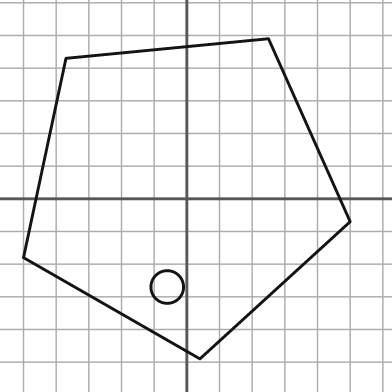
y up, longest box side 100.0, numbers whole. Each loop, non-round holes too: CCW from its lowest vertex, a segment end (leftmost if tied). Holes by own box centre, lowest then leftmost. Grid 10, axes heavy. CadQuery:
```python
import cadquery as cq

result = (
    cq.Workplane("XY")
    .moveTo(4.0, -49.0)
    .lineTo(50.0, -7.0)
    .lineTo(25.0, 49.0)
    .lineTo(-37.0, 43.0)
    .lineTo(-50.0, -18.0)
    .close()
    .moveTo(-6.0, -27.0)
    .circle(5.0)
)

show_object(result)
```